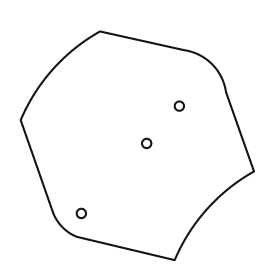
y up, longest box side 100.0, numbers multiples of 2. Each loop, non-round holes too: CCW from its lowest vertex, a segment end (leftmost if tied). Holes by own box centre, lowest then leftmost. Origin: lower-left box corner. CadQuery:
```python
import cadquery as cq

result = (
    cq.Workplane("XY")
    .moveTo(66.0, 0.0)
    .threePointArc((80.0, 22.0), (100.0, 38.0))
    .lineTo(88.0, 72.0)
    .threePointArc((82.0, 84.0), (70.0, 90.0))
    .lineTo(34.0, 98.0)
    .threePointArc((14.0, 82.0), (0.0, 60.0))
    .lineTo(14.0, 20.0)
    .threePointArc((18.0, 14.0), (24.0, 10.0))
    .close()
    .moveTo(26.0, 20.0)
    .circle(2.0)
    .moveTo(54.0, 50.0)
    .circle(2.0)
    .moveTo(68.0, 66.0)
    .circle(2.0)
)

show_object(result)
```